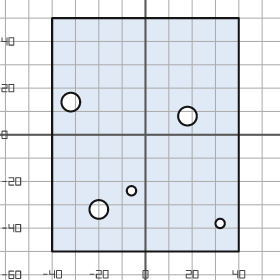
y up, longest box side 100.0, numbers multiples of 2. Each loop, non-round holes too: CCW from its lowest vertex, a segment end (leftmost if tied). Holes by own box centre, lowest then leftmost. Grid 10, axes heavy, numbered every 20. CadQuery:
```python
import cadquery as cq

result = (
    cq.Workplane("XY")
    .moveTo(-40.0, -50.0)
    .lineTo(40.0, -50.0)
    .lineTo(40.0, 50.0)
    .lineTo(-40.0, 50.0)
    .close()
    .moveTo(32.0, -38.0)
    .circle(2.0)
    .moveTo(-20.0, -32.0)
    .circle(4.0)
    .moveTo(-6.0, -24.0)
    .circle(2.0)
    .moveTo(18.0, 8.0)
    .circle(4.0)
    .moveTo(-32.0, 14.0)
    .circle(4.0)
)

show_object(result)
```